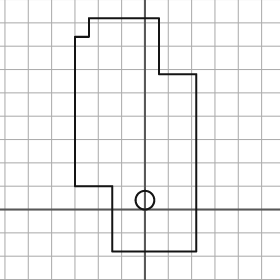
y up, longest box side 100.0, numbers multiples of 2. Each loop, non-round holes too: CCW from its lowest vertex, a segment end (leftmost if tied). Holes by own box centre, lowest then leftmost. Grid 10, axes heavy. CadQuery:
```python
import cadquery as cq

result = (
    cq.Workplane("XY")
    .moveTo(-14.0, -18.0)
    .lineTo(22.0, -18.0)
    .lineTo(22.0, 58.0)
    .lineTo(6.0, 58.0)
    .lineTo(6.0, 82.0)
    .lineTo(-24.0, 82.0)
    .lineTo(-24.0, 74.0)
    .lineTo(-30.0, 74.0)
    .lineTo(-30.0, 10.0)
    .lineTo(-14.0, 10.0)
    .close()
    .moveTo(0.0, 4.0)
    .circle(4.0)
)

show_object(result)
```